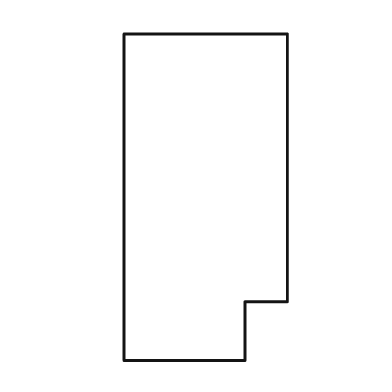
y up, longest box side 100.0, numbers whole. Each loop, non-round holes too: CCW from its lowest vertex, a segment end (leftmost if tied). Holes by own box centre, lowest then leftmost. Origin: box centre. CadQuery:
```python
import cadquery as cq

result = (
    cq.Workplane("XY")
    .moveTo(-25.0, -50.0)
    .lineTo(12.0, -50.0)
    .lineTo(12.0, -32.0)
    .lineTo(25.0, -32.0)
    .lineTo(25.0, 50.0)
    .lineTo(-25.0, 50.0)
    .close()
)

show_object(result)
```